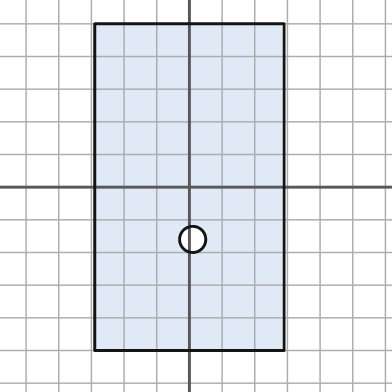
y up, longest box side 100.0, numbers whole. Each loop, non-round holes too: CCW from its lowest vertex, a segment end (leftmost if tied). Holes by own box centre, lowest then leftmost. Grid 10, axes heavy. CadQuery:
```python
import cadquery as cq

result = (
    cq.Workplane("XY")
    .moveTo(-29.0, -50.0)
    .lineTo(29.0, -50.0)
    .lineTo(29.0, 50.0)
    .lineTo(-29.0, 50.0)
    .close()
    .moveTo(1.0, -16.0)
    .circle(4.0)
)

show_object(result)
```